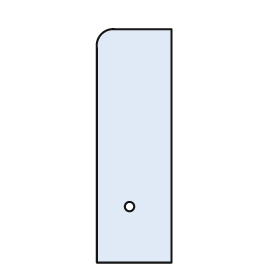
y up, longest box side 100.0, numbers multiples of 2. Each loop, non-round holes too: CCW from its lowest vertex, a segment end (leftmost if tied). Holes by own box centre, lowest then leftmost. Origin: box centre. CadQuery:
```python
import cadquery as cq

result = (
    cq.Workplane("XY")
    .moveTo(-16.0, -50.0)
    .lineTo(16.0, -50.0)
    .lineTo(16.0, 50.0)
    .lineTo(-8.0, 50.0)
    .threePointArc((-14.0, 48.0), (-16.0, 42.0))
    .close()
    .moveTo(-2.0, -26.0)
    .circle(2.0)
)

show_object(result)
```